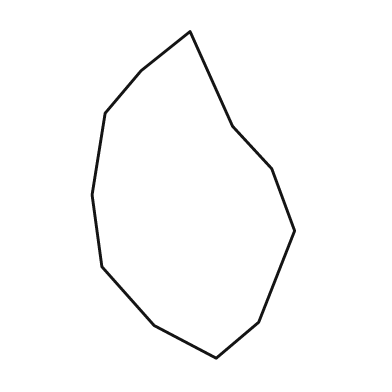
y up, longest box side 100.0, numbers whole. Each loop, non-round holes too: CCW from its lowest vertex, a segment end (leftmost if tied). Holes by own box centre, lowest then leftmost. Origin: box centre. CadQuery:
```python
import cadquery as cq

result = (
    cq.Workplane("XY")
    .moveTo(7.0, -50.0)
    .lineTo(20.0, -39.0)
    .lineTo(31.0, -11.0)
    .lineTo(24.0, 8.0)
    .lineTo(12.0, 21.0)
    .lineTo(-1.0, 50.0)
    .lineTo(-16.0, 38.0)
    .lineTo(-27.0, 25.0)
    .lineTo(-31.0, 0.0)
    .lineTo(-28.0, -22.0)
    .lineTo(-12.0, -40.0)
    .close()
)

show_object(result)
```